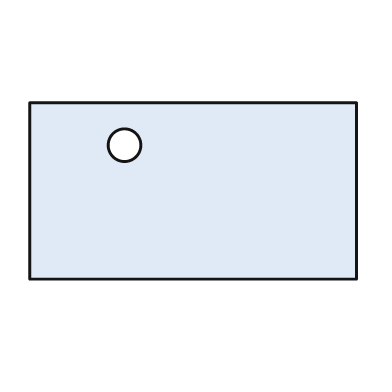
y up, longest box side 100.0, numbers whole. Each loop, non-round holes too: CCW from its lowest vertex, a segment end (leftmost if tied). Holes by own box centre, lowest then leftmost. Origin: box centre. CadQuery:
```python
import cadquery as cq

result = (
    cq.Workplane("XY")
    .moveTo(-50.0, -27.0)
    .lineTo(50.0, -27.0)
    .lineTo(50.0, 27.0)
    .lineTo(-50.0, 27.0)
    .close()
    .moveTo(-21.0, 14.0)
    .circle(5.0)
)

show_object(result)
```